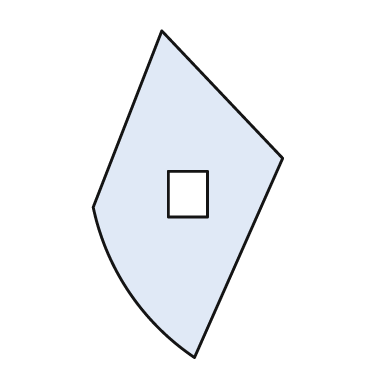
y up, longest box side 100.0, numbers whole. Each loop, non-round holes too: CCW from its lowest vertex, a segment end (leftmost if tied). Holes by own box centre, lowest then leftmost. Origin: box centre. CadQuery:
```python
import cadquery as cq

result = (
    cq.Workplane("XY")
    .moveTo(2.0, -50.0)
    .lineTo(29.0, 11.0)
    .lineTo(-8.0, 50.0)
    .lineTo(-29.0, -4.0)
    .threePointArc((-18.0, -30.0), (2.0, -50.0))
    .close()
    .moveTo(-6.0, -7.0)
    .lineTo(6.0, -7.0)
    .lineTo(6.0, 7.0)
    .lineTo(-6.0, 7.0)
    .close()
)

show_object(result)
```